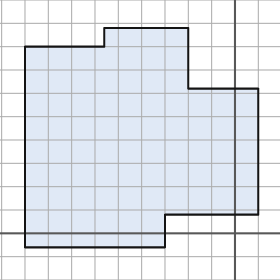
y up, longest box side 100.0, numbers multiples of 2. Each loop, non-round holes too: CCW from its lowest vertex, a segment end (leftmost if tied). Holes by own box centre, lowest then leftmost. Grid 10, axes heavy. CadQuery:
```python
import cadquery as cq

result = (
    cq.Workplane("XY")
    .moveTo(-90.0, -6.0)
    .lineTo(-30.0, -6.0)
    .lineTo(-30.0, 8.0)
    .lineTo(10.0, 8.0)
    .lineTo(10.0, 62.0)
    .lineTo(-20.0, 62.0)
    .lineTo(-20.0, 88.0)
    .lineTo(-56.0, 88.0)
    .lineTo(-56.0, 80.0)
    .lineTo(-90.0, 80.0)
    .close()
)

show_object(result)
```